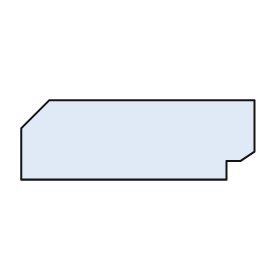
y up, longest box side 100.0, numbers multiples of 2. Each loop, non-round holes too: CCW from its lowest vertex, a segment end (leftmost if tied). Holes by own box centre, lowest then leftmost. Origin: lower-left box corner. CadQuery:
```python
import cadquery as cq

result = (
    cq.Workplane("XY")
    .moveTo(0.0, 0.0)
    .lineTo(88.0, 0.0)
    .lineTo(88.0, 8.0)
    .lineTo(94.0, 8.0)
    .lineTo(100.0, 12.0)
    .lineTo(100.0, 34.0)
    .lineTo(12.0, 34.0)
    .lineTo(0.0, 22.0)
    .close()
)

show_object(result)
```